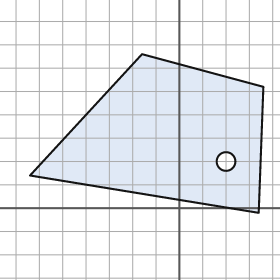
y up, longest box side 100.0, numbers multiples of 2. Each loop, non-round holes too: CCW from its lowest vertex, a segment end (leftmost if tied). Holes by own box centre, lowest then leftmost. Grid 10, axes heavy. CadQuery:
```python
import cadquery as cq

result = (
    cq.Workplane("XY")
    .moveTo(34.0, -2.0)
    .lineTo(36.0, 52.0)
    .lineTo(-16.0, 66.0)
    .lineTo(-64.0, 14.0)
    .close()
    .moveTo(20.0, 20.0)
    .circle(4.0)
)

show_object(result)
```